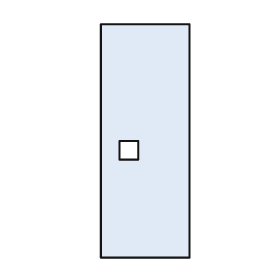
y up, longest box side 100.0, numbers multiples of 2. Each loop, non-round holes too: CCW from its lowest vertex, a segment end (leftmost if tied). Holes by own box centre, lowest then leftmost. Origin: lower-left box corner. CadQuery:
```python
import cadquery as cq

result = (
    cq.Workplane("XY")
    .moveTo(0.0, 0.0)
    .lineTo(38.0, 0.0)
    .lineTo(38.0, 100.0)
    .lineTo(0.0, 100.0)
    .close()
    .moveTo(8.0, 42.0)
    .lineTo(16.0, 42.0)
    .lineTo(16.0, 50.0)
    .lineTo(8.0, 50.0)
    .close()
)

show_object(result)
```